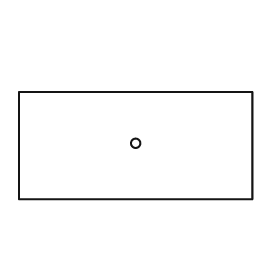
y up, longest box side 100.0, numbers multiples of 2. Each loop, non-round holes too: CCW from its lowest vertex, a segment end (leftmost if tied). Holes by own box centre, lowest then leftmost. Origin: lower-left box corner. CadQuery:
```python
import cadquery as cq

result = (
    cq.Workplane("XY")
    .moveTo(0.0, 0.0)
    .lineTo(100.0, 0.0)
    .lineTo(100.0, 46.0)
    .lineTo(0.0, 46.0)
    .close()
    .moveTo(50.0, 24.0)
    .circle(2.0)
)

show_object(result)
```